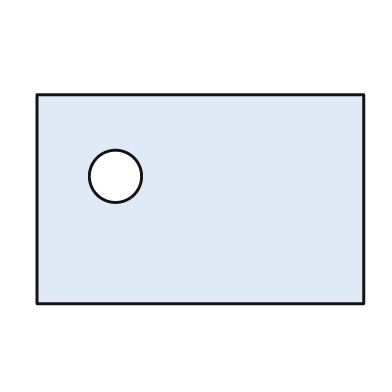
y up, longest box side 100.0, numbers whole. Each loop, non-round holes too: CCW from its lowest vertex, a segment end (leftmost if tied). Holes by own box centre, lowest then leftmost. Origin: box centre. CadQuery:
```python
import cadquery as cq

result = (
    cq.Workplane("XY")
    .moveTo(-50.0, -32.0)
    .lineTo(50.0, -32.0)
    .lineTo(50.0, 32.0)
    .lineTo(-50.0, 32.0)
    .close()
    .moveTo(-26.0, 7.0)
    .circle(8.0)
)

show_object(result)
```